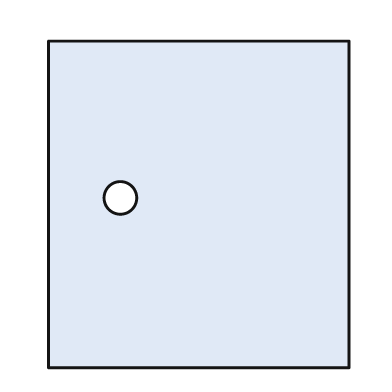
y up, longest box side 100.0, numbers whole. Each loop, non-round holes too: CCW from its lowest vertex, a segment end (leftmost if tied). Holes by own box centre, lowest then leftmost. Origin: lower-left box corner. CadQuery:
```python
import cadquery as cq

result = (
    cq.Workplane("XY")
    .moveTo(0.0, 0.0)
    .lineTo(92.0, 0.0)
    .lineTo(92.0, 100.0)
    .lineTo(0.0, 100.0)
    .close()
    .moveTo(22.0, 52.0)
    .circle(5.0)
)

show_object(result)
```